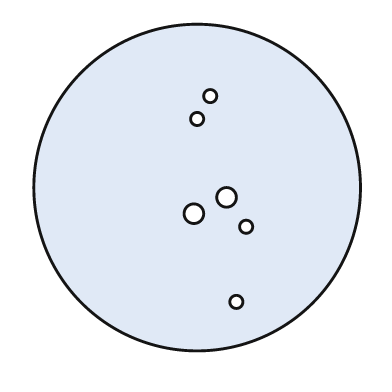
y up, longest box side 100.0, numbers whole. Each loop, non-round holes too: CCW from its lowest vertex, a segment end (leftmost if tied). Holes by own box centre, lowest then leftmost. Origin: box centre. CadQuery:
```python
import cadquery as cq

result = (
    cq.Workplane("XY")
    .moveTo(0.0, 0.0)
    .circle(50.0)
    .moveTo(12.0, -35.0)
    .circle(2.0)
    .moveTo(15.0, -12.0)
    .circle(2.0)
    .moveTo(-1.0, -8.0)
    .circle(3.0)
    .moveTo(9.0, -3.0)
    .circle(3.0)
    .moveTo(0.0, 21.0)
    .circle(2.0)
    .moveTo(4.0, 28.0)
    .circle(2.0)
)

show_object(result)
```